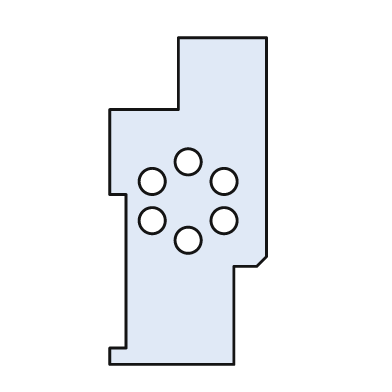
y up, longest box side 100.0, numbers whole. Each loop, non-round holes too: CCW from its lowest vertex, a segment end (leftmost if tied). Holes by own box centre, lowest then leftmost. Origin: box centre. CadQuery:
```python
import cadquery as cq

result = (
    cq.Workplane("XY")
    .moveTo(-24.0, -50.0)
    .lineTo(14.0, -50.0)
    .lineTo(14.0, -20.0)
    .lineTo(21.0, -20.0)
    .lineTo(24.0, -17.0)
    .lineTo(24.0, 50.0)
    .lineTo(-3.0, 50.0)
    .lineTo(-3.0, 28.0)
    .lineTo(-24.0, 28.0)
    .lineTo(-24.0, 2.0)
    .lineTo(-19.0, 2.0)
    .lineTo(-19.0, -45.0)
    .lineTo(-24.0, -45.0)
    .close()
    .moveTo(0.0, -12.0)
    .circle(4.0)
    .moveTo(-11.0, -6.0)
    .circle(4.0)
    .moveTo(11.0, -6.0)
    .circle(4.0)
    .moveTo(-11.0, 6.0)
    .circle(4.0)
    .moveTo(11.0, 6.0)
    .circle(4.0)
    .moveTo(0.0, 12.0)
    .circle(4.0)
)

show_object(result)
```